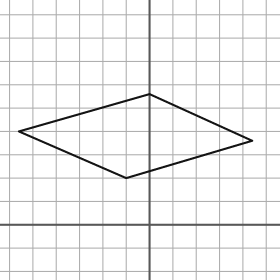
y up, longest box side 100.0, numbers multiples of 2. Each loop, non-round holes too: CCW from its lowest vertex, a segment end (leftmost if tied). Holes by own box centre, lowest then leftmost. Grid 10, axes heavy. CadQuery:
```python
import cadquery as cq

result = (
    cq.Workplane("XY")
    .moveTo(-10.0, 20.0)
    .lineTo(44.0, 36.0)
    .lineTo(0.0, 56.0)
    .lineTo(-56.0, 40.0)
    .close()
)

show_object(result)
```